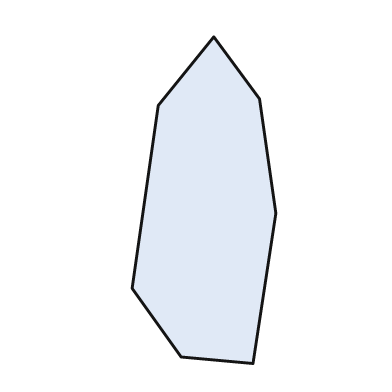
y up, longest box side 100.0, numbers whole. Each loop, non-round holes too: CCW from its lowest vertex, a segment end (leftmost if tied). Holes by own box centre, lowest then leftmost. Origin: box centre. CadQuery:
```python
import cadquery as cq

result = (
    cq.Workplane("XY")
    .moveTo(15.0, -50.0)
    .lineTo(22.0, -4.0)
    .lineTo(17.0, 31.0)
    .lineTo(3.0, 50.0)
    .lineTo(-14.0, 29.0)
    .lineTo(-22.0, -27.0)
    .lineTo(-7.0, -48.0)
    .close()
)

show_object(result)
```